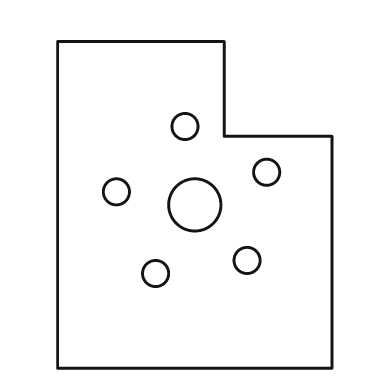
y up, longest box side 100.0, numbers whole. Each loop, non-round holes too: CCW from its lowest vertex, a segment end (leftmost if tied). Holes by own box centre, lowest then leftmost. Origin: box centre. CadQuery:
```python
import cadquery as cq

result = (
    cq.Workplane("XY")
    .moveTo(-42.0, -50.0)
    .lineTo(42.0, -50.0)
    .lineTo(42.0, 21.0)
    .lineTo(9.0, 21.0)
    .lineTo(9.0, 50.0)
    .lineTo(-42.0, 50.0)
    .close()
    .moveTo(-12.0, -21.0)
    .circle(4.0)
    .moveTo(16.0, -17.0)
    .circle(4.0)
    .moveTo(0.0, 0.0)
    .circle(8.0)
    .moveTo(-24.0, 4.0)
    .circle(4.0)
    .moveTo(22.0, 10.0)
    .circle(4.0)
    .moveTo(-3.0, 24.0)
    .circle(4.0)
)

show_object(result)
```